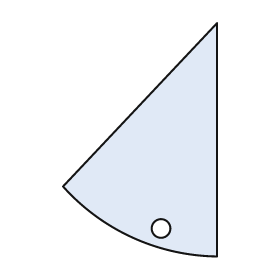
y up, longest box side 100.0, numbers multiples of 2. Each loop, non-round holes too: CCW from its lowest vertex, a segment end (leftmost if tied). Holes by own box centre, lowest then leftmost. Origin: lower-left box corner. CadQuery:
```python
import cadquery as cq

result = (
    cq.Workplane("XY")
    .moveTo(66.0, 0.0)
    .lineTo(66.0, 100.0)
    .lineTo(0.0, 30.0)
    .threePointArc((30.0, 8.0), (66.0, 0.0))
    .close()
    .moveTo(42.0, 12.0)
    .circle(4.0)
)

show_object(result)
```